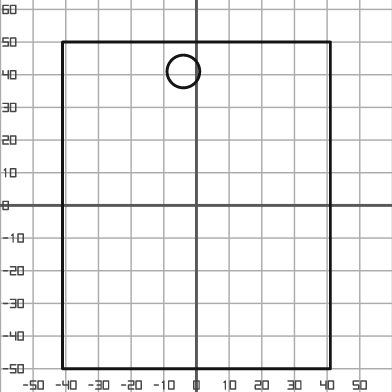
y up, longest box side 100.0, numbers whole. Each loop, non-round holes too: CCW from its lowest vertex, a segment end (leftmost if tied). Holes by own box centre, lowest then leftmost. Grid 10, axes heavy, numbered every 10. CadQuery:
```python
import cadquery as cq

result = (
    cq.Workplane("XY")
    .moveTo(-41.0, -50.0)
    .lineTo(41.0, -50.0)
    .lineTo(41.0, 50.0)
    .lineTo(-41.0, 50.0)
    .close()
    .moveTo(-4.0, 41.0)
    .circle(5.0)
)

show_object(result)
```